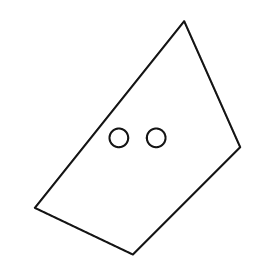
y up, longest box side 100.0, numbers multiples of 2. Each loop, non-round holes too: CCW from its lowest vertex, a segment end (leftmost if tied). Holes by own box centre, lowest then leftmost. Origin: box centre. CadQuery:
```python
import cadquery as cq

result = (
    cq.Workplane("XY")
    .moveTo(-2.0, -50.0)
    .lineTo(44.0, -4.0)
    .lineTo(20.0, 50.0)
    .lineTo(-44.0, -30.0)
    .close()
    .moveTo(-8.0, 0.0)
    .circle(4.0)
    .moveTo(8.0, 0.0)
    .circle(4.0)
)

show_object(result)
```